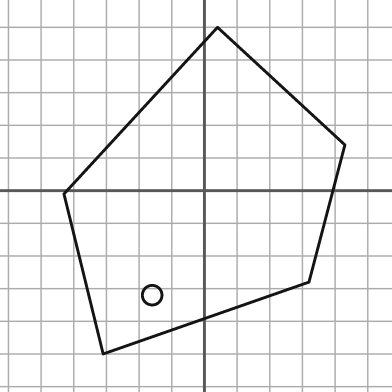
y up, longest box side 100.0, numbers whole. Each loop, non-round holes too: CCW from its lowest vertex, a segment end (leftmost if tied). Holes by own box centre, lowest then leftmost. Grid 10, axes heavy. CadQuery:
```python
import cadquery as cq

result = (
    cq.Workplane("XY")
    .moveTo(-31.0, -50.0)
    .lineTo(32.0, -28.0)
    .lineTo(43.0, 14.0)
    .lineTo(4.0, 50.0)
    .lineTo(-43.0, -1.0)
    .close()
    .moveTo(-16.0, -32.0)
    .circle(3.0)
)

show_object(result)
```